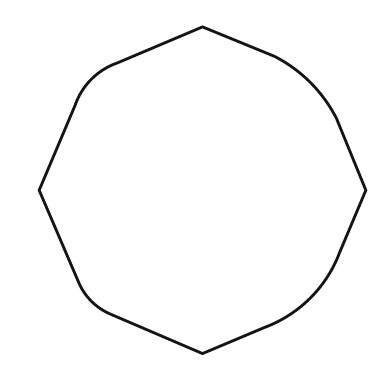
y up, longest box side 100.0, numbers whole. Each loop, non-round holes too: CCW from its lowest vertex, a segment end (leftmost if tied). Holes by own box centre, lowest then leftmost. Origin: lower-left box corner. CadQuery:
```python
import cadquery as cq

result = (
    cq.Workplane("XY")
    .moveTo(50.0, 0.0)
    .lineTo(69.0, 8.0)
    .threePointArc((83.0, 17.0), (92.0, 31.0))
    .lineTo(100.0, 50.0)
    .lineTo(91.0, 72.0)
    .threePointArc((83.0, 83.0), (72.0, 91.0))
    .lineTo(50.0, 100.0)
    .lineTo(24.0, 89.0)
    .threePointArc((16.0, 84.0), (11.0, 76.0))
    .lineTo(0.0, 50.0)
    .lineTo(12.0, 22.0)
    .threePointArc((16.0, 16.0), (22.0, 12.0))
    .close()
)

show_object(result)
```